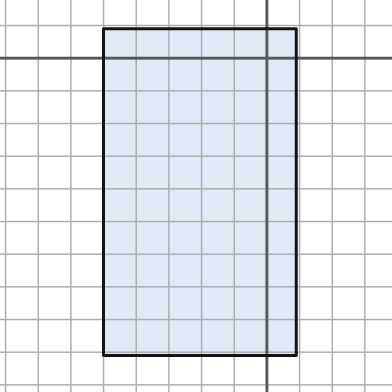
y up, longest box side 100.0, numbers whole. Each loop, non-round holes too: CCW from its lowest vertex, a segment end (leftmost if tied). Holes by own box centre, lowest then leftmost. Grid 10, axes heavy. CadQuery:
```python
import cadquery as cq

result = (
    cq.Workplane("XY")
    .moveTo(-50.0, -91.0)
    .lineTo(9.0, -91.0)
    .lineTo(9.0, 9.0)
    .lineTo(-50.0, 9.0)
    .close()
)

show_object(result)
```